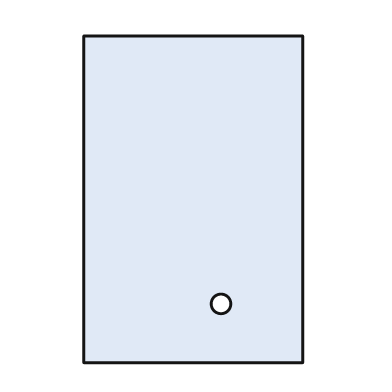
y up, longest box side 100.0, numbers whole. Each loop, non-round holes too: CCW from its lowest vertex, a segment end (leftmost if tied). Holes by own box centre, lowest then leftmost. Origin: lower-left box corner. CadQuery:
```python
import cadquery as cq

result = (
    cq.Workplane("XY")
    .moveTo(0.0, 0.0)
    .lineTo(67.0, 0.0)
    .lineTo(67.0, 100.0)
    .lineTo(0.0, 100.0)
    .close()
    .moveTo(42.0, 18.0)
    .circle(3.0)
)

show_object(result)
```